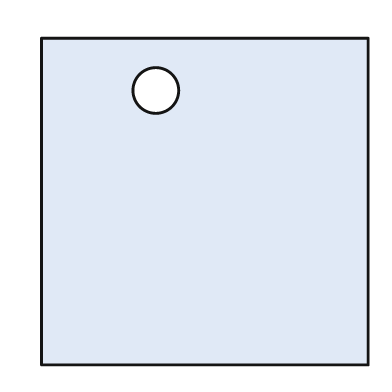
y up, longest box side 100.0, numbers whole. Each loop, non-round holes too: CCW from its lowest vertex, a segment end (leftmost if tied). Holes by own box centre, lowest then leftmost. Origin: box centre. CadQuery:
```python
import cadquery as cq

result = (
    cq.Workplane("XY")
    .moveTo(-50.0, -50.0)
    .lineTo(50.0, -50.0)
    .lineTo(50.0, 50.0)
    .lineTo(-50.0, 50.0)
    .close()
    .moveTo(-15.0, 34.0)
    .circle(7.0)
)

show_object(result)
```